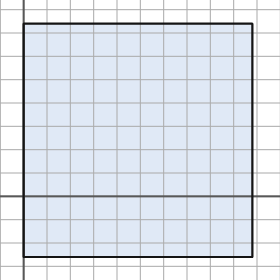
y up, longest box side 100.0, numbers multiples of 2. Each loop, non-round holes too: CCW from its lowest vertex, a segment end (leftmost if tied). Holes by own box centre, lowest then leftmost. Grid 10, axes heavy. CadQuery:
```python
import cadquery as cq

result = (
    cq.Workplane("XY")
    .moveTo(0.0, -26.0)
    .lineTo(98.0, -26.0)
    .lineTo(98.0, 74.0)
    .lineTo(0.0, 74.0)
    .close()
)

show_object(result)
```